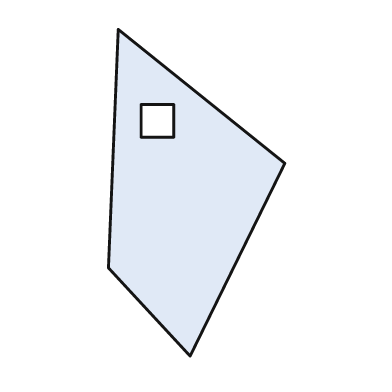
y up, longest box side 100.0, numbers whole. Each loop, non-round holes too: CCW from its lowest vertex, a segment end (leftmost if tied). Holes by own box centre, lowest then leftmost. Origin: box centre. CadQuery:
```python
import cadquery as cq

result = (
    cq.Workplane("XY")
    .moveTo(-2.0, -50.0)
    .lineTo(27.0, 9.0)
    .lineTo(-24.0, 50.0)
    .lineTo(-27.0, -23.0)
    .close()
    .moveTo(-17.0, 17.0)
    .lineTo(-7.0, 17.0)
    .lineTo(-7.0, 27.0)
    .lineTo(-17.0, 27.0)
    .close()
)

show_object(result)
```